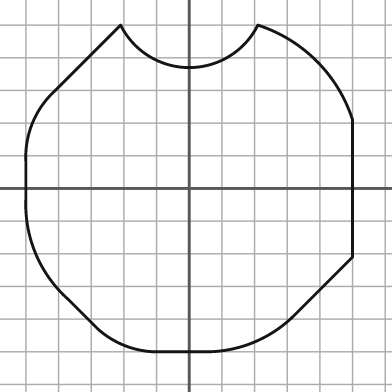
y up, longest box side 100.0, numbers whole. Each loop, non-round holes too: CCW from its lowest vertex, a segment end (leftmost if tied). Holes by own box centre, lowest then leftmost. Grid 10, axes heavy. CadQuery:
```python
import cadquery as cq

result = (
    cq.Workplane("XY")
    .moveTo(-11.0, -50.0)
    .lineTo(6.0, -50.0)
    .threePointArc((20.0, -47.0), (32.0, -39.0))
    .lineTo(50.0, -21.0)
    .lineTo(50.0, 21.0)
    .threePointArc((39.0, 39.0), (21.0, 50.0))
    .threePointArc((0.0, 37.0), (-21.0, 50.0))
    .lineTo(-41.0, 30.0)
    .threePointArc((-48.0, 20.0), (-50.0, 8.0))
    .lineTo(-50.0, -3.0)
    .threePointArc((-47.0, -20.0), (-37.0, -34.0))
    .lineTo(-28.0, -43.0)
    .threePointArc((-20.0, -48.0), (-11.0, -50.0))
    .close()
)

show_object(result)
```